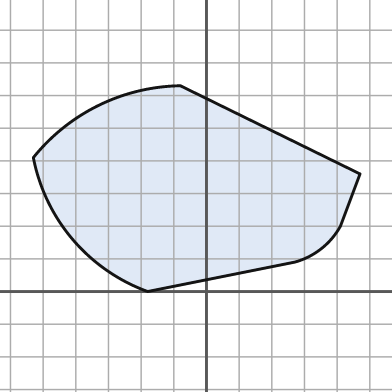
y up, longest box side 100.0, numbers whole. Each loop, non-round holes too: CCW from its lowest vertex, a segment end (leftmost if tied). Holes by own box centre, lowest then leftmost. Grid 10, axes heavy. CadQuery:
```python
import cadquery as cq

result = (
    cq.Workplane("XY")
    .moveTo(-18.0, 0.0)
    .lineTo(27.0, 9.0)
    .threePointArc((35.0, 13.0), (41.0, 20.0))
    .lineTo(47.0, 36.0)
    .lineTo(-8.0, 63.0)
    .threePointArc((-33.0, 57.0), (-53.0, 41.0))
    .threePointArc((-41.0, 16.0), (-18.0, 0.0))
    .close()
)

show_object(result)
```